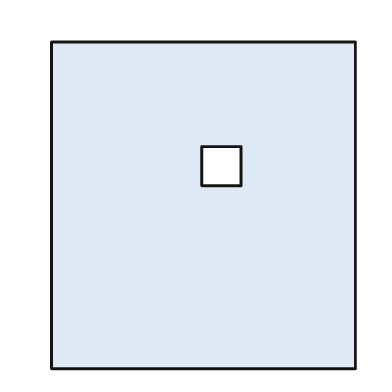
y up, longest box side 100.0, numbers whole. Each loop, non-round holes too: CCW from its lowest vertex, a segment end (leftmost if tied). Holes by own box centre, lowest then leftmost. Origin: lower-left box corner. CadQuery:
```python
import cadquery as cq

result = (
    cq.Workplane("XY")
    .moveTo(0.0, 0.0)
    .lineTo(93.0, 0.0)
    .lineTo(93.0, 100.0)
    .lineTo(0.0, 100.0)
    .close()
    .moveTo(46.0, 56.0)
    .lineTo(58.0, 56.0)
    .lineTo(58.0, 68.0)
    .lineTo(46.0, 68.0)
    .close()
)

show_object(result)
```